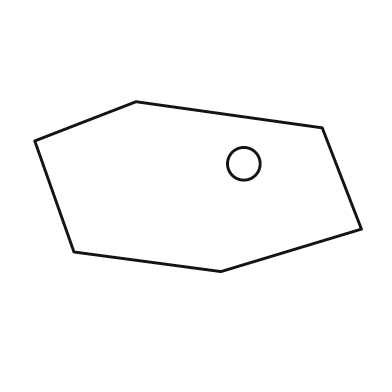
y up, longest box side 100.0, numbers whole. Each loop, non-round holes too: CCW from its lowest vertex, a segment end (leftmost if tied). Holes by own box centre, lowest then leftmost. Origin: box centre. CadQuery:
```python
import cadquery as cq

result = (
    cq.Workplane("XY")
    .moveTo(7.0, -26.0)
    .lineTo(50.0, -13.0)
    .lineTo(38.0, 18.0)
    .lineTo(-19.0, 26.0)
    .lineTo(-50.0, 14.0)
    .lineTo(-38.0, -20.0)
    .close()
    .moveTo(14.0, 7.0)
    .circle(5.0)
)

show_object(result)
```